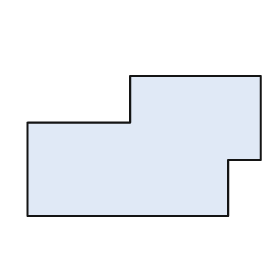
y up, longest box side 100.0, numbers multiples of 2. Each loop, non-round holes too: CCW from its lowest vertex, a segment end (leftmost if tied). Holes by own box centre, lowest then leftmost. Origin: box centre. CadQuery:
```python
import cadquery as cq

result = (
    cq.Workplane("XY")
    .moveTo(-50.0, -30.0)
    .lineTo(36.0, -30.0)
    .lineTo(36.0, -6.0)
    .lineTo(50.0, -6.0)
    .lineTo(50.0, 30.0)
    .lineTo(-6.0, 30.0)
    .lineTo(-6.0, 10.0)
    .lineTo(-50.0, 10.0)
    .close()
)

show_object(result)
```